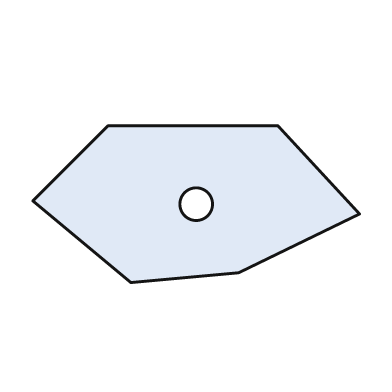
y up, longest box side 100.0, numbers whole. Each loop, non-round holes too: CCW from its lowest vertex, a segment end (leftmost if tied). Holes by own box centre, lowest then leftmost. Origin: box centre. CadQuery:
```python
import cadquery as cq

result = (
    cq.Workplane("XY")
    .moveTo(-20.0, -24.0)
    .lineTo(13.0, -21.0)
    .lineTo(50.0, -3.0)
    .lineTo(25.0, 24.0)
    .lineTo(-27.0, 24.0)
    .lineTo(-50.0, 1.0)
    .close()
    .moveTo(0.0, 0.0)
    .circle(5.0)
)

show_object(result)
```